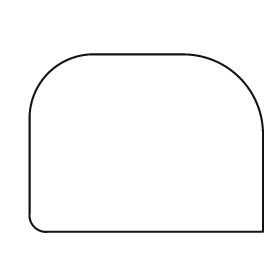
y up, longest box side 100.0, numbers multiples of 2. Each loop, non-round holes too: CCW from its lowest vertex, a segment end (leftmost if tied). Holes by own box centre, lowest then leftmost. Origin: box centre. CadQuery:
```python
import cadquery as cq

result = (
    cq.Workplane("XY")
    .moveTo(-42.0, -38.0)
    .lineTo(50.0, -38.0)
    .lineTo(50.0, 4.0)
    .threePointArc((40.0, 28.0), (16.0, 38.0))
    .lineTo(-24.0, 38.0)
    .threePointArc((-42.0, 30.0), (-50.0, 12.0))
    .lineTo(-50.0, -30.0)
    .threePointArc((-48.0, -36.0), (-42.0, -38.0))
    .close()
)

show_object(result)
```